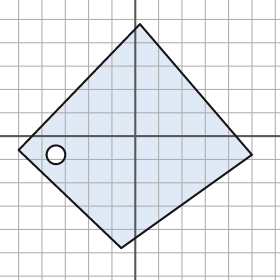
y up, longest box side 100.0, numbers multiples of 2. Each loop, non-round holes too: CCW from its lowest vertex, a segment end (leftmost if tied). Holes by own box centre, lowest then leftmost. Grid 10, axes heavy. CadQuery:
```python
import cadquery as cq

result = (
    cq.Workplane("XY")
    .moveTo(-6.0, -48.0)
    .lineTo(50.0, -8.0)
    .lineTo(2.0, 48.0)
    .lineTo(-50.0, -6.0)
    .close()
    .moveTo(-34.0, -8.0)
    .circle(4.0)
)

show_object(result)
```